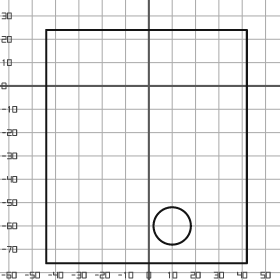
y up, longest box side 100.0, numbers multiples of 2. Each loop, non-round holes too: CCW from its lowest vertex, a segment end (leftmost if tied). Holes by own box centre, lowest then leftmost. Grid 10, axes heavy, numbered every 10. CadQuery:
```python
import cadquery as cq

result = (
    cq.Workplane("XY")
    .moveTo(-44.0, -76.0)
    .lineTo(42.0, -76.0)
    .lineTo(42.0, 24.0)
    .lineTo(-44.0, 24.0)
    .close()
    .moveTo(10.0, -60.0)
    .circle(8.0)
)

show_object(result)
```